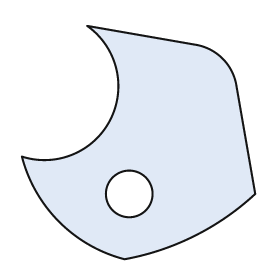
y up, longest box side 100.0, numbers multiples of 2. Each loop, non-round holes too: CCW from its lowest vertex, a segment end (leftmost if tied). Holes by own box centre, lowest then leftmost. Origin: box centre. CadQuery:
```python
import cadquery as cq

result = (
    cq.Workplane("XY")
    .moveTo(-6.0, -50.0)
    .threePointArc((24.0, -40.0), (50.0, -22.0))
    .lineTo(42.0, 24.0)
    .threePointArc((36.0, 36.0), (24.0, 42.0))
    .lineTo(-22.0, 50.0)
    .threePointArc((-12.0, 10.0), (-50.0, -6.0))
    .threePointArc((-34.0, -34.0), (-6.0, -50.0))
    .close()
    .moveTo(-4.0, -22.0)
    .circle(10.0)
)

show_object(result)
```